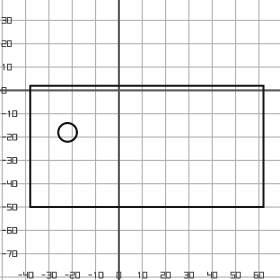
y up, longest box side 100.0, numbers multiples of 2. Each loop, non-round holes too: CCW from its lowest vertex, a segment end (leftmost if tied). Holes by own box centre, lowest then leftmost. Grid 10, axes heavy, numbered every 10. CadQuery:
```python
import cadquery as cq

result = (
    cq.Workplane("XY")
    .moveTo(-38.0, -50.0)
    .lineTo(62.0, -50.0)
    .lineTo(62.0, 2.0)
    .lineTo(-38.0, 2.0)
    .close()
    .moveTo(-22.0, -18.0)
    .circle(4.0)
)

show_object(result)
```